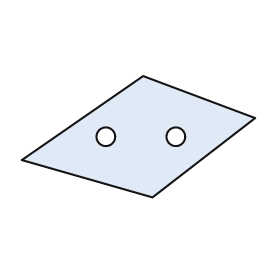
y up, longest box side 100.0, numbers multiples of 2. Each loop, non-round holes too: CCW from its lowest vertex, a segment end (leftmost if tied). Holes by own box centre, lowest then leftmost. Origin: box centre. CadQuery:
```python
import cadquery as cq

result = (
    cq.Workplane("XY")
    .moveTo(6.0, -26.0)
    .lineTo(50.0, 8.0)
    .lineTo(2.0, 26.0)
    .lineTo(-50.0, -10.0)
    .close()
    .moveTo(-14.0, 0.0)
    .circle(4.0)
    .moveTo(16.0, 0.0)
    .circle(4.0)
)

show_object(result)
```